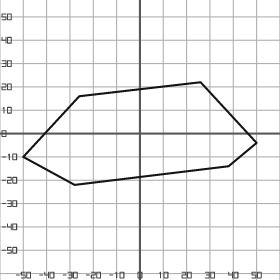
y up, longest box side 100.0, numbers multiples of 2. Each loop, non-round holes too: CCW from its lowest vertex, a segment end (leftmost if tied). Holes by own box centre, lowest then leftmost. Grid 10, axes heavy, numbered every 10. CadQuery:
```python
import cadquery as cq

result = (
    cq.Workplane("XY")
    .moveTo(-28.0, -22.0)
    .lineTo(38.0, -14.0)
    .lineTo(50.0, -4.0)
    .lineTo(26.0, 22.0)
    .lineTo(-26.0, 16.0)
    .lineTo(-50.0, -10.0)
    .close()
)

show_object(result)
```